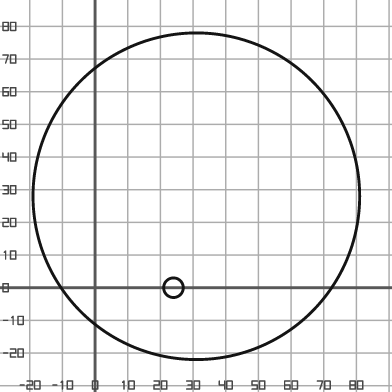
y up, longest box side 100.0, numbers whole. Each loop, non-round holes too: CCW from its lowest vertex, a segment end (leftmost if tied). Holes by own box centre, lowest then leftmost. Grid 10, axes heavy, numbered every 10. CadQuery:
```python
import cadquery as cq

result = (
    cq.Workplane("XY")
    .moveTo(31.0, 28.0)
    .circle(50.0)
    .moveTo(24.0, 0.0)
    .circle(3.0)
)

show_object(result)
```